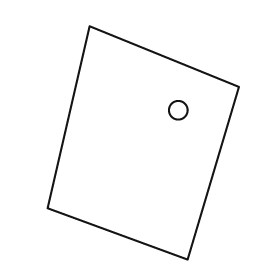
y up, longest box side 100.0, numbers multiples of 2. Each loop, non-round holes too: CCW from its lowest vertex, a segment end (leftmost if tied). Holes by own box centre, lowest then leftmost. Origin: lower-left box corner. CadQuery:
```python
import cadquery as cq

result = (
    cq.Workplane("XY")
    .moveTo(60.0, 0.0)
    .lineTo(82.0, 74.0)
    .lineTo(18.0, 100.0)
    .lineTo(0.0, 22.0)
    .close()
    .moveTo(56.0, 64.0)
    .circle(4.0)
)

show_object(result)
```